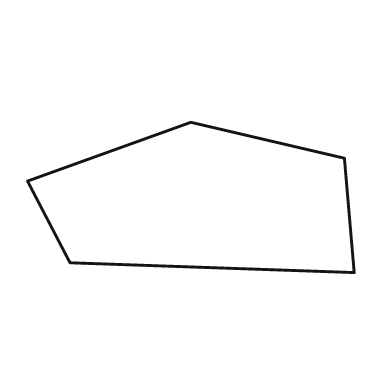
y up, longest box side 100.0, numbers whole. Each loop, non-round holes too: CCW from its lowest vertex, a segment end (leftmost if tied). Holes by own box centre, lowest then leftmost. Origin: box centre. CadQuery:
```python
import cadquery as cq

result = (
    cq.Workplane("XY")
    .moveTo(50.0, -23.0)
    .lineTo(47.0, 12.0)
    .lineTo(0.0, 23.0)
    .lineTo(-50.0, 5.0)
    .lineTo(-37.0, -20.0)
    .close()
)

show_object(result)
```